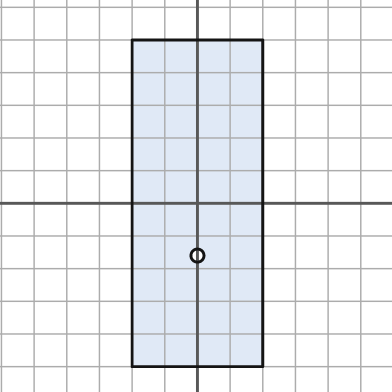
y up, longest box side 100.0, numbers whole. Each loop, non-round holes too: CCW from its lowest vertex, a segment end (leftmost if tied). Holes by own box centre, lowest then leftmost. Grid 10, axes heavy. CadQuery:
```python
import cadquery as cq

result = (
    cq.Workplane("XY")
    .moveTo(-20.0, -50.0)
    .lineTo(20.0, -50.0)
    .lineTo(20.0, 50.0)
    .lineTo(-20.0, 50.0)
    .close()
    .moveTo(0.0, -16.0)
    .circle(2.0)
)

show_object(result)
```